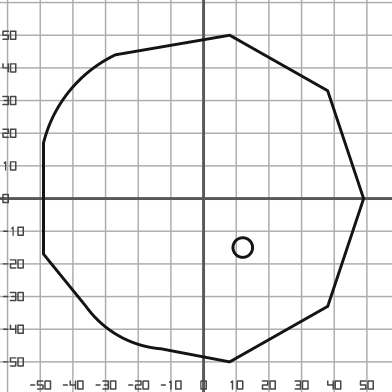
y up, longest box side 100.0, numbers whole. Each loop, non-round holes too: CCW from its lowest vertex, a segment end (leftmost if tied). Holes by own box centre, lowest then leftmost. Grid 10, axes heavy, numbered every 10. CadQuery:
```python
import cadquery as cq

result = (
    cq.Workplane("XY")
    .moveTo(8.0, -50.0)
    .lineTo(38.0, -33.0)
    .lineTo(49.0, 0.0)
    .lineTo(38.0, 33.0)
    .lineTo(8.0, 50.0)
    .lineTo(-27.0, 44.0)
    .threePointArc((-41.0, 33.0), (-49.0, 17.0))
    .lineTo(-49.0, -17.0)
    .lineTo(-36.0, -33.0)
    .threePointArc((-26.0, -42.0), (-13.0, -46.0))
    .close()
    .moveTo(12.0, -15.0)
    .circle(3.0)
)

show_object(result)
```